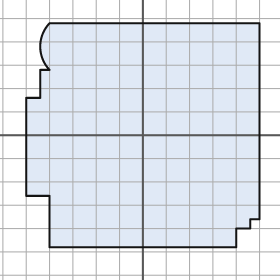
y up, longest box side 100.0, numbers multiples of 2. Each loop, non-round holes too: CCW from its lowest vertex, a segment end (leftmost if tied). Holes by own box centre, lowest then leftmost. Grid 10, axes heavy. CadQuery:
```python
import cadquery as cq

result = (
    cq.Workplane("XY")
    .moveTo(-40.0, -48.0)
    .lineTo(40.0, -48.0)
    .lineTo(40.0, -40.0)
    .lineTo(46.0, -40.0)
    .lineTo(46.0, -36.0)
    .lineTo(50.0, -36.0)
    .lineTo(50.0, 48.0)
    .lineTo(-40.0, 48.0)
    .threePointArc((-44.0, 38.0), (-40.0, 28.0))
    .lineTo(-44.0, 28.0)
    .lineTo(-44.0, 16.0)
    .lineTo(-50.0, 16.0)
    .lineTo(-50.0, -26.0)
    .lineTo(-40.0, -26.0)
    .close()
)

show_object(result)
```